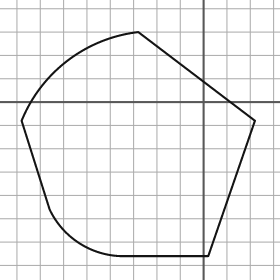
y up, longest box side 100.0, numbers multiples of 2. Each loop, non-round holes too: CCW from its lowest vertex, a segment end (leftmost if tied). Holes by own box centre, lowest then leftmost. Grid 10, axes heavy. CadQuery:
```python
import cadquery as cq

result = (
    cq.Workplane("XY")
    .moveTo(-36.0, -66.0)
    .lineTo(2.0, -66.0)
    .lineTo(22.0, -8.0)
    .lineTo(-28.0, 30.0)
    .threePointArc((-58.0, 18.0), (-78.0, -8.0))
    .lineTo(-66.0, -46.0)
    .threePointArc((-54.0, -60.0), (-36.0, -66.0))
    .close()
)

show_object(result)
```